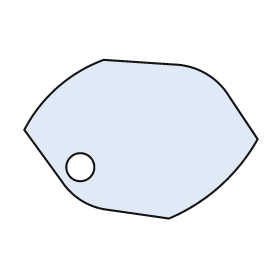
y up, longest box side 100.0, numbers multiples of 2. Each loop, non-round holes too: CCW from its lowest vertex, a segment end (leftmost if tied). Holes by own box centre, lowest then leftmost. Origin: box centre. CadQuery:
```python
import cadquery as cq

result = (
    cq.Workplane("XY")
    .moveTo(12.0, -34.0)
    .threePointArc((34.0, -20.0), (50.0, 0.0))
    .lineTo(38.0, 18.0)
    .threePointArc((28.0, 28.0), (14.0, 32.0))
    .lineTo(-16.0, 34.0)
    .threePointArc((-36.0, 22.0), (-50.0, 4.0))
    .lineTo(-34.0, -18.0)
    .threePointArc((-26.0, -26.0), (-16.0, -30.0))
    .close()
    .moveTo(-26.0, -12.0)
    .circle(6.0)
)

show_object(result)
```